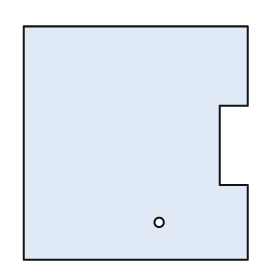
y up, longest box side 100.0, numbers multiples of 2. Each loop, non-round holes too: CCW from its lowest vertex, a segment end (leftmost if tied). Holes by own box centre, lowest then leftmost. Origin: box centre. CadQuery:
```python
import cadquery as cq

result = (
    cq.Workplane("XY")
    .moveTo(-48.0, -50.0)
    .lineTo(48.0, -50.0)
    .lineTo(48.0, -18.0)
    .lineTo(36.0, -18.0)
    .lineTo(36.0, 16.0)
    .lineTo(48.0, 16.0)
    .lineTo(48.0, 50.0)
    .lineTo(-48.0, 50.0)
    .close()
    .moveTo(10.0, -34.0)
    .circle(2.0)
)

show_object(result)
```